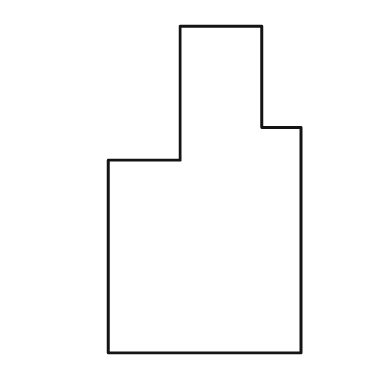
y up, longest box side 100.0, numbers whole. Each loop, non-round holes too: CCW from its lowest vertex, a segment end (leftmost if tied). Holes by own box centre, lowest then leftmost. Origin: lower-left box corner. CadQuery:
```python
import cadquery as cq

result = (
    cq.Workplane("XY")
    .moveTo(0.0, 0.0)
    .lineTo(59.0, 0.0)
    .lineTo(59.0, 69.0)
    .lineTo(47.0, 69.0)
    .lineTo(47.0, 100.0)
    .lineTo(22.0, 100.0)
    .lineTo(22.0, 59.0)
    .lineTo(0.0, 59.0)
    .close()
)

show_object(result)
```